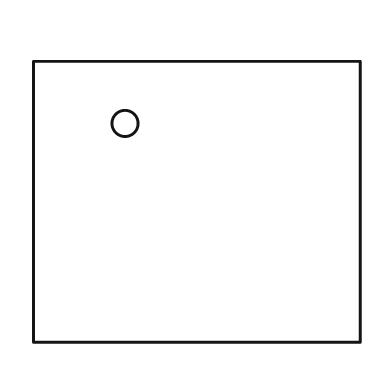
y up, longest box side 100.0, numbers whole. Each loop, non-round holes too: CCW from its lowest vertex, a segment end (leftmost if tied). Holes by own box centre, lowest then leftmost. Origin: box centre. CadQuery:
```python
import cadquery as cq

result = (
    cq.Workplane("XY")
    .moveTo(-50.0, -43.0)
    .lineTo(50.0, -43.0)
    .lineTo(50.0, 43.0)
    .lineTo(-50.0, 43.0)
    .close()
    .moveTo(-22.0, 24.0)
    .circle(4.0)
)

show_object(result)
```